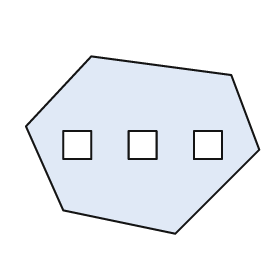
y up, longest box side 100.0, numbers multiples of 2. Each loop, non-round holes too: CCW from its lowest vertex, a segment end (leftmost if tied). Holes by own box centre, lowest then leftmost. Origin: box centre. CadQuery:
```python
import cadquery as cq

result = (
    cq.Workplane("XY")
    .moveTo(14.0, -38.0)
    .lineTo(50.0, -2.0)
    .lineTo(38.0, 30.0)
    .lineTo(-22.0, 38.0)
    .lineTo(-50.0, 8.0)
    .lineTo(-34.0, -28.0)
    .close()
    .moveTo(-34.0, -6.0)
    .lineTo(-22.0, -6.0)
    .lineTo(-22.0, 6.0)
    .lineTo(-34.0, 6.0)
    .close()
    .moveTo(-6.0, -6.0)
    .lineTo(6.0, -6.0)
    .lineTo(6.0, 6.0)
    .lineTo(-6.0, 6.0)
    .close()
    .moveTo(22.0, -6.0)
    .lineTo(34.0, -6.0)
    .lineTo(34.0, 6.0)
    .lineTo(22.0, 6.0)
    .close()
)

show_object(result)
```